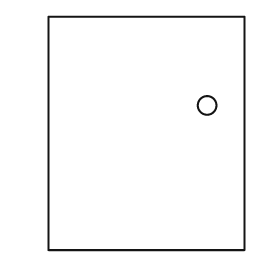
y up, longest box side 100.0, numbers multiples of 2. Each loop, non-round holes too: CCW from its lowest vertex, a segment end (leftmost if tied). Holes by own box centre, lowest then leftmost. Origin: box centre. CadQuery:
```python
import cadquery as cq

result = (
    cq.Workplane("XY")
    .moveTo(-42.0, -50.0)
    .lineTo(42.0, -50.0)
    .lineTo(42.0, 50.0)
    .lineTo(-42.0, 50.0)
    .close()
    .moveTo(26.0, 12.0)
    .circle(4.0)
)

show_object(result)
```